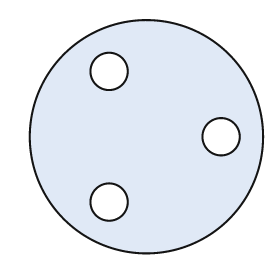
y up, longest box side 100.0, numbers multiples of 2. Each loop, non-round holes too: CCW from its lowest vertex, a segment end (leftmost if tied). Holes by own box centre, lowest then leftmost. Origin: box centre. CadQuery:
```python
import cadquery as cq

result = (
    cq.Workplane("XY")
    .moveTo(0.0, 0.0)
    .circle(50.0)
    .moveTo(-16.0, -28.0)
    .circle(8.0)
    .moveTo(32.0, 0.0)
    .circle(8.0)
    .moveTo(-16.0, 28.0)
    .circle(8.0)
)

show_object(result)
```